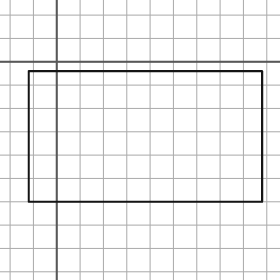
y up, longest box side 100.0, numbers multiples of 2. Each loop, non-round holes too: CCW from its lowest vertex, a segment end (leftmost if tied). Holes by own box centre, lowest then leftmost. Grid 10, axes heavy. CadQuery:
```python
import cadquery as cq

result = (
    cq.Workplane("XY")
    .moveTo(-12.0, -60.0)
    .lineTo(88.0, -60.0)
    .lineTo(88.0, -4.0)
    .lineTo(-12.0, -4.0)
    .close()
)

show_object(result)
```